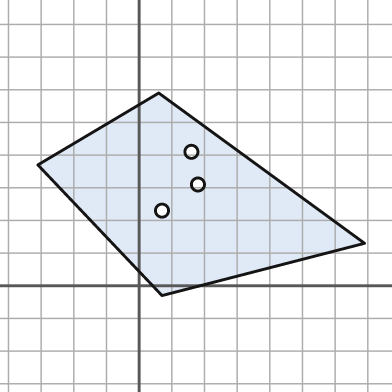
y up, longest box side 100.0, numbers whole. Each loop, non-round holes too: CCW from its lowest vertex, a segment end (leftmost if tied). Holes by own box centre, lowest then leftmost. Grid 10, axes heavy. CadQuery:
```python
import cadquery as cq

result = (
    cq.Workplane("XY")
    .moveTo(7.0, -3.0)
    .lineTo(69.0, 13.0)
    .lineTo(6.0, 59.0)
    .lineTo(-31.0, 37.0)
    .close()
    .moveTo(7.0, 23.0)
    .circle(2.0)
    .moveTo(18.0, 31.0)
    .circle(2.0)
    .moveTo(16.0, 41.0)
    .circle(2.0)
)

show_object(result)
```